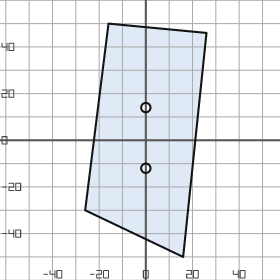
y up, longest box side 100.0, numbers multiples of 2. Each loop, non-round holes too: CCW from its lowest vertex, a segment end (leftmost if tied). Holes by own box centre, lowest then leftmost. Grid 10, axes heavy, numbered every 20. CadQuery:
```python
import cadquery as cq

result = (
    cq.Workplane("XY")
    .moveTo(16.0, -50.0)
    .lineTo(26.0, 46.0)
    .lineTo(-16.0, 50.0)
    .lineTo(-26.0, -30.0)
    .close()
    .moveTo(0.0, -12.0)
    .circle(2.0)
    .moveTo(0.0, 14.0)
    .circle(2.0)
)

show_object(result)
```